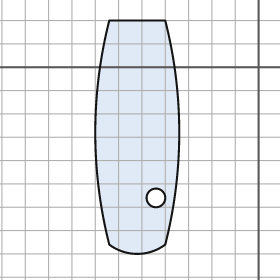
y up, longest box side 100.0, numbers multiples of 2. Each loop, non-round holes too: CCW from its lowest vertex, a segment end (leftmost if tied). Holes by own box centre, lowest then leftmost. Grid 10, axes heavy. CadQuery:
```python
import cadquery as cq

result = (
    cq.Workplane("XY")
    .moveTo(-64.0, -76.0)
    .threePointArc((-52.0, -80.0), (-40.0, -76.0))
    .threePointArc((-34.0, -28.0), (-40.0, 20.0))
    .lineTo(-64.0, 20.0)
    .threePointArc((-70.0, -28.0), (-64.0, -76.0))
    .close()
    .moveTo(-44.0, -56.0)
    .circle(4.0)
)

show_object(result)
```